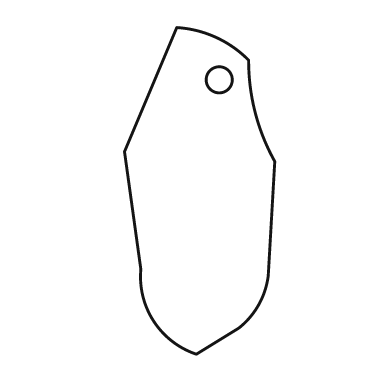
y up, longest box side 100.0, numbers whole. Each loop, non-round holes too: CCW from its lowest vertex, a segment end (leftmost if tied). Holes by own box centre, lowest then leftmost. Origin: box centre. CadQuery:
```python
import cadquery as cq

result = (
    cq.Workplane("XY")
    .moveTo(-1.0, -50.0)
    .lineTo(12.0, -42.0)
    .threePointArc((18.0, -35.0), (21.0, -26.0))
    .lineTo(23.0, 9.0)
    .threePointArc((17.0, 24.0), (15.0, 40.0))
    .threePointArc((5.0, 47.0), (-7.0, 50.0))
    .lineTo(-23.0, 12.0)
    .lineTo(-18.0, -24.0)
    .threePointArc((-14.0, -40.0), (-1.0, -50.0))
    .close()
    .moveTo(6.0, 34.0)
    .circle(4.0)
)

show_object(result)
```